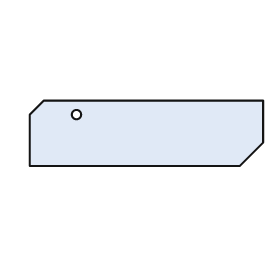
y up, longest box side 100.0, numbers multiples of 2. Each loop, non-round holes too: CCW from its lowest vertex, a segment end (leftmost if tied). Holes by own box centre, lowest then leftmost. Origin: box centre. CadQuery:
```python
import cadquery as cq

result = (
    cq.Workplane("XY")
    .moveTo(-50.0, -14.0)
    .lineTo(40.0, -14.0)
    .lineTo(50.0, -4.0)
    .lineTo(50.0, 14.0)
    .lineTo(-44.0, 14.0)
    .lineTo(-50.0, 8.0)
    .close()
    .moveTo(-30.0, 8.0)
    .circle(2.0)
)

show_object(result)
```